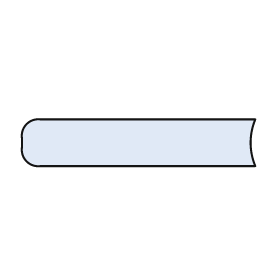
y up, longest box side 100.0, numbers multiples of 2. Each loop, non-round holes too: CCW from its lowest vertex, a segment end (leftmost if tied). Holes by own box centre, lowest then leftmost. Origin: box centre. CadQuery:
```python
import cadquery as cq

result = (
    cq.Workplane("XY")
    .moveTo(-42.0, -10.0)
    .lineTo(50.0, -10.0)
    .threePointArc((48.0, 0.0), (50.0, 10.0))
    .lineTo(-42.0, 10.0)
    .threePointArc((-48.0, 8.0), (-50.0, 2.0))
    .lineTo(-50.0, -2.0)
    .threePointArc((-48.0, -8.0), (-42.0, -10.0))
    .close()
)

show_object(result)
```